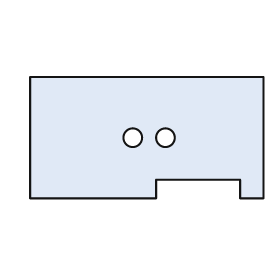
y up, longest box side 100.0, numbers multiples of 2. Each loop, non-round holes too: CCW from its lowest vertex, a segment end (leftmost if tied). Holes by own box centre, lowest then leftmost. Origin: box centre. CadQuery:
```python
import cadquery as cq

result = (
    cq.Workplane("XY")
    .moveTo(-50.0, -26.0)
    .lineTo(4.0, -26.0)
    .lineTo(4.0, -18.0)
    .lineTo(40.0, -18.0)
    .lineTo(40.0, -26.0)
    .lineTo(50.0, -26.0)
    .lineTo(50.0, 26.0)
    .lineTo(-50.0, 26.0)
    .close()
    .moveTo(-6.0, 0.0)
    .circle(4.0)
    .moveTo(8.0, 0.0)
    .circle(4.0)
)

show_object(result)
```